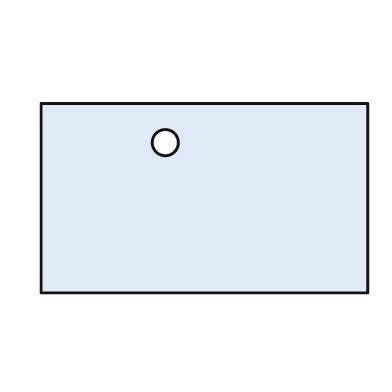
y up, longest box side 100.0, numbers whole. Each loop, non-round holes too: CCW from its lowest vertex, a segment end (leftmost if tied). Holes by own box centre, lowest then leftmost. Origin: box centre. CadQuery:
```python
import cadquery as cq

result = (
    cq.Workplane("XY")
    .moveTo(-50.0, -29.0)
    .lineTo(50.0, -29.0)
    .lineTo(50.0, 29.0)
    .lineTo(-50.0, 29.0)
    .close()
    .moveTo(-12.0, 17.0)
    .circle(4.0)
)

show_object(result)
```